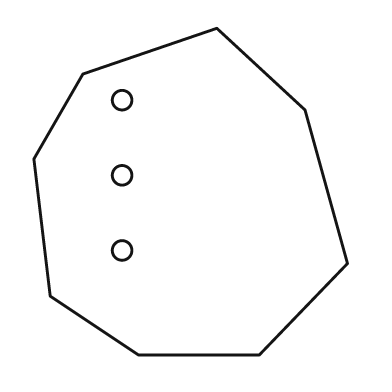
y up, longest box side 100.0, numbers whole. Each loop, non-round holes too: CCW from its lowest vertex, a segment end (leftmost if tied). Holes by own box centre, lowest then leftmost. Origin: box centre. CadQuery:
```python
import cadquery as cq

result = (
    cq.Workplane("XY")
    .moveTo(-16.0, -50.0)
    .lineTo(21.0, -50.0)
    .lineTo(48.0, -22.0)
    .lineTo(35.0, 25.0)
    .lineTo(8.0, 50.0)
    .lineTo(-33.0, 36.0)
    .lineTo(-48.0, 10.0)
    .lineTo(-43.0, -32.0)
    .close()
    .moveTo(-21.0, -18.0)
    .circle(3.0)
    .moveTo(-21.0, 5.0)
    .circle(3.0)
    .moveTo(-21.0, 28.0)
    .circle(3.0)
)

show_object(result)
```